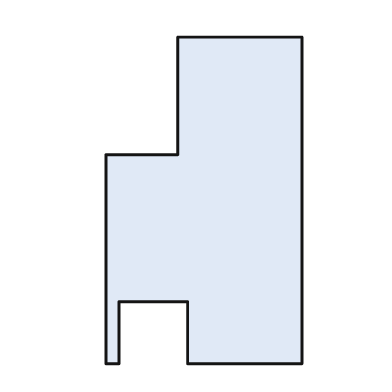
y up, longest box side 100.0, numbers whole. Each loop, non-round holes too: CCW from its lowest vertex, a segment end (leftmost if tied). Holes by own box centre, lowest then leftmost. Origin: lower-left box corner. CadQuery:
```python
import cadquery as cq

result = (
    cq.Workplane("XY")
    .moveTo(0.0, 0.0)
    .lineTo(4.0, 0.0)
    .lineTo(4.0, 19.0)
    .lineTo(25.0, 19.0)
    .lineTo(25.0, 0.0)
    .lineTo(60.0, 0.0)
    .lineTo(60.0, 100.0)
    .lineTo(22.0, 100.0)
    .lineTo(22.0, 64.0)
    .lineTo(0.0, 64.0)
    .close()
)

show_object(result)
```